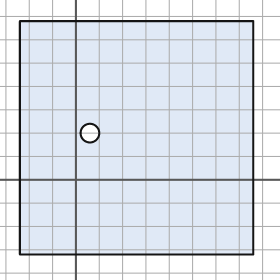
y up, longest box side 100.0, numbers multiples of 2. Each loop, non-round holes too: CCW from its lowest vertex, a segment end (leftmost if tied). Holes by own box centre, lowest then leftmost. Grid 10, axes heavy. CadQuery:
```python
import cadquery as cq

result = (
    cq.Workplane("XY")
    .moveTo(-24.0, -32.0)
    .lineTo(76.0, -32.0)
    .lineTo(76.0, 68.0)
    .lineTo(-24.0, 68.0)
    .close()
    .moveTo(6.0, 20.0)
    .circle(4.0)
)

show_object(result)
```